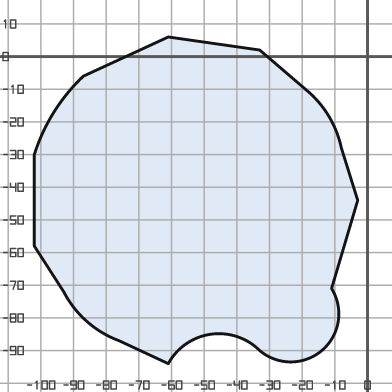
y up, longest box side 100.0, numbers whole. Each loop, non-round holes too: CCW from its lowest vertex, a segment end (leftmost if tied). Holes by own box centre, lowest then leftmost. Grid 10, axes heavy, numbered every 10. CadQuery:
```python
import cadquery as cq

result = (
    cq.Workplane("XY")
    .moveTo(-61.0, -94.0)
    .threePointArc((-48.0, -85.0), (-33.0, -90.0))
    .threePointArc((-14.0, -90.0), (-11.0, -71.0))
    .lineTo(-3.0, -44.0)
    .lineTo(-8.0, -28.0)
    .threePointArc((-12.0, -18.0), (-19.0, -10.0))
    .lineTo(-33.0, 2.0)
    .lineTo(-61.0, 6.0)
    .lineTo(-87.0, -6.0)
    .threePointArc((-96.0, -17.0), (-102.0, -30.0))
    .lineTo(-102.0, -58.0)
    .lineTo(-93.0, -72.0)
    .threePointArc((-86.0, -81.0), (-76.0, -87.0))
    .close()
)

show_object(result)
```